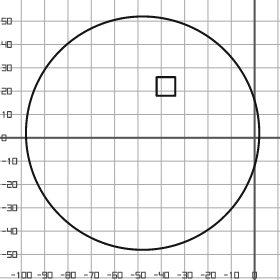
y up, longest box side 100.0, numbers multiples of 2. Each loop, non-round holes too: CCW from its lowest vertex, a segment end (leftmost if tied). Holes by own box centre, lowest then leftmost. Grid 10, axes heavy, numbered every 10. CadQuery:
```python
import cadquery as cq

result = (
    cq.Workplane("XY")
    .moveTo(-48.0, 2.0)
    .circle(50.0)
    .moveTo(-42.0, 18.0)
    .lineTo(-34.0, 18.0)
    .lineTo(-34.0, 26.0)
    .lineTo(-42.0, 26.0)
    .close()
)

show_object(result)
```